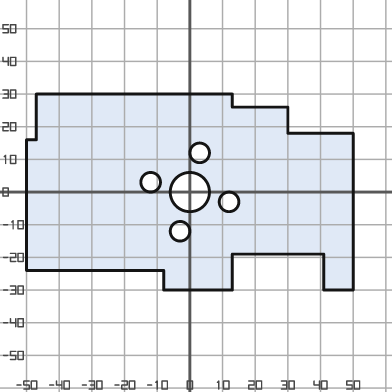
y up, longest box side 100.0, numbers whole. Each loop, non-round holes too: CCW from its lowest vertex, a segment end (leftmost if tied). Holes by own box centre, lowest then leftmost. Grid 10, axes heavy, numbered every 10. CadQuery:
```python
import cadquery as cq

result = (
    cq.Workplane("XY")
    .moveTo(-8.0, -30.0)
    .lineTo(13.0, -30.0)
    .lineTo(13.0, -19.0)
    .lineTo(41.0, -19.0)
    .lineTo(41.0, -30.0)
    .lineTo(50.0, -30.0)
    .lineTo(50.0, 18.0)
    .lineTo(30.0, 18.0)
    .lineTo(30.0, 26.0)
    .lineTo(13.0, 26.0)
    .lineTo(13.0, 30.0)
    .lineTo(-47.0, 30.0)
    .lineTo(-47.0, 16.0)
    .lineTo(-50.0, 16.0)
    .lineTo(-50.0, -24.0)
    .lineTo(-8.0, -24.0)
    .close()
    .moveTo(-3.0, -12.0)
    .circle(3.0)
    .moveTo(12.0, -3.0)
    .circle(3.0)
    .moveTo(0.0, 0.0)
    .circle(6.0)
    .moveTo(-12.0, 3.0)
    .circle(3.0)
    .moveTo(3.0, 12.0)
    .circle(3.0)
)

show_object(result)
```